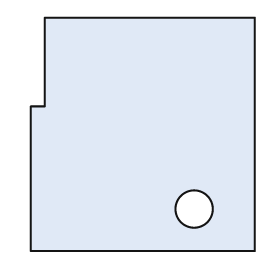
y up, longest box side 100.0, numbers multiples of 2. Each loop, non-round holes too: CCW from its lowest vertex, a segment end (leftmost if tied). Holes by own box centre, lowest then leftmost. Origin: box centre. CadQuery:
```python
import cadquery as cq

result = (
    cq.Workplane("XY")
    .moveTo(-48.0, -50.0)
    .lineTo(48.0, -50.0)
    .lineTo(48.0, 50.0)
    .lineTo(-42.0, 50.0)
    .lineTo(-42.0, 12.0)
    .lineTo(-48.0, 12.0)
    .close()
    .moveTo(22.0, -32.0)
    .circle(8.0)
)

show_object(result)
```